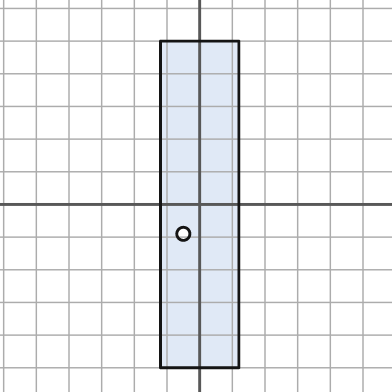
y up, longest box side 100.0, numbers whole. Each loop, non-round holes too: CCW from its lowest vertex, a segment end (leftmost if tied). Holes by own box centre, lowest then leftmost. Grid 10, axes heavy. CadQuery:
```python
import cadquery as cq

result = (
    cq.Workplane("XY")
    .moveTo(-12.0, -50.0)
    .lineTo(12.0, -50.0)
    .lineTo(12.0, 50.0)
    .lineTo(-12.0, 50.0)
    .close()
    .moveTo(-5.0, -9.0)
    .circle(2.0)
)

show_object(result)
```